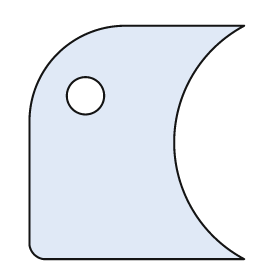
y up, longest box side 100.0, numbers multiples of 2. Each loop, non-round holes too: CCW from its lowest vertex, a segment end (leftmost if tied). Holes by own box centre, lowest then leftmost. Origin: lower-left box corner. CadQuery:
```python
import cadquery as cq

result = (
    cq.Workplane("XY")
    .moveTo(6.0, 0.0)
    .lineTo(92.0, 0.0)
    .threePointArc((62.0, 50.0), (92.0, 100.0))
    .lineTo(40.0, 100.0)
    .threePointArc((12.0, 88.0), (0.0, 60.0))
    .lineTo(0.0, 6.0)
    .threePointArc((2.0, 2.0), (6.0, 0.0))
    .close()
    .moveTo(24.0, 70.0)
    .circle(8.0)
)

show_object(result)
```